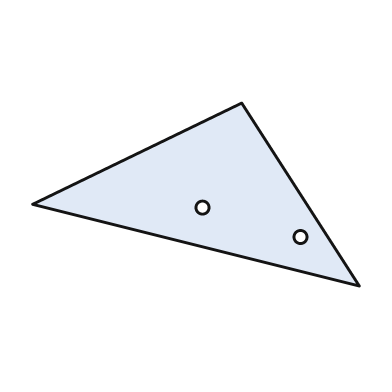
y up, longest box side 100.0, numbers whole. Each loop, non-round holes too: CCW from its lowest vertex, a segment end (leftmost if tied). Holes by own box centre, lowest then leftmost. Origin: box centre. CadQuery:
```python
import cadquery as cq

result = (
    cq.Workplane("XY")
    .moveTo(50.0, -28.0)
    .lineTo(14.0, 28.0)
    .lineTo(-50.0, -3.0)
    .close()
    .moveTo(32.0, -13.0)
    .circle(2.0)
    .moveTo(2.0, -4.0)
    .circle(2.0)
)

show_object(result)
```